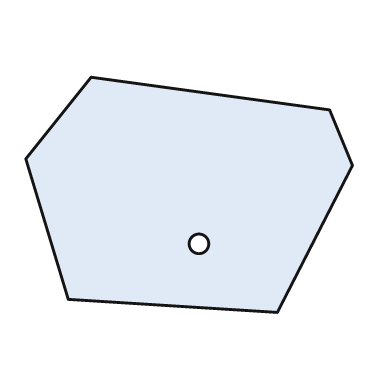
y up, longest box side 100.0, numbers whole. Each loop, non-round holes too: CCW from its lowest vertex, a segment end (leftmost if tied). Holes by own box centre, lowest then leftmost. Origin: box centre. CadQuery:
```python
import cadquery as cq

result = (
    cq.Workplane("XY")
    .moveTo(27.0, -36.0)
    .lineTo(50.0, 9.0)
    .lineTo(43.0, 26.0)
    .lineTo(-30.0, 36.0)
    .lineTo(-50.0, 11.0)
    .lineTo(-37.0, -32.0)
    .close()
    .moveTo(3.0, -15.0)
    .circle(3.0)
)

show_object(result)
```